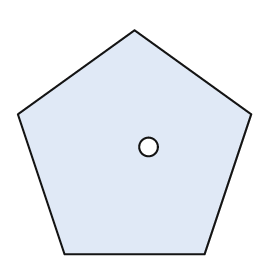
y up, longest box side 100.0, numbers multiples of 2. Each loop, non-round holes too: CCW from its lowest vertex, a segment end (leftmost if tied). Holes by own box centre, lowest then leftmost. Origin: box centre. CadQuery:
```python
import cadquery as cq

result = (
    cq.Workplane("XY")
    .moveTo(-30.0, -48.0)
    .lineTo(30.0, -48.0)
    .lineTo(50.0, 12.0)
    .lineTo(0.0, 48.0)
    .lineTo(-50.0, 12.0)
    .close()
    .moveTo(6.0, -2.0)
    .circle(4.0)
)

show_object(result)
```